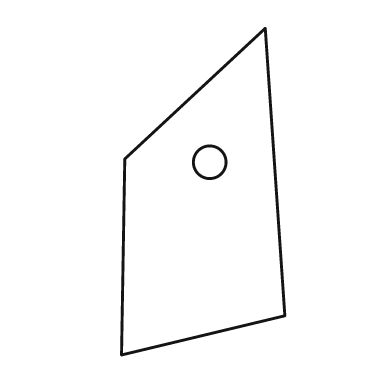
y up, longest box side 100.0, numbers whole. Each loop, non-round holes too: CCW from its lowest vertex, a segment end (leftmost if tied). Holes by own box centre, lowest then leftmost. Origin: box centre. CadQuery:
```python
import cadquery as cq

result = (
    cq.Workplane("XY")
    .moveTo(-25.0, -50.0)
    .lineTo(25.0, -38.0)
    .lineTo(19.0, 50.0)
    .lineTo(-24.0, 10.0)
    .close()
    .moveTo(2.0, 9.0)
    .circle(5.0)
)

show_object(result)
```